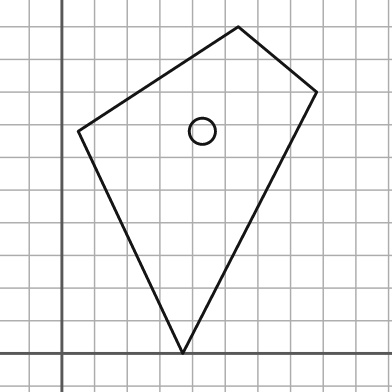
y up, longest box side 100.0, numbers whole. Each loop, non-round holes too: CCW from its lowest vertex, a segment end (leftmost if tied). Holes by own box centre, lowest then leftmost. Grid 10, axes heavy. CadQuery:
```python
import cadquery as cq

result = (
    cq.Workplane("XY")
    .moveTo(37.0, 0.0)
    .lineTo(78.0, 80.0)
    .lineTo(54.0, 100.0)
    .lineTo(5.0, 68.0)
    .close()
    .moveTo(43.0, 68.0)
    .circle(4.0)
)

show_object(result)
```